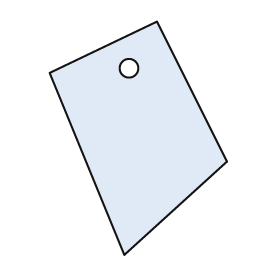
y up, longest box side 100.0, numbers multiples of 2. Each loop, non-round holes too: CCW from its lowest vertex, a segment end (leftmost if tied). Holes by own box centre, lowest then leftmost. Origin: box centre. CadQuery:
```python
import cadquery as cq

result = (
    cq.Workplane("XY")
    .moveTo(-6.0, -50.0)
    .lineTo(38.0, -10.0)
    .lineTo(8.0, 50.0)
    .lineTo(-38.0, 28.0)
    .close()
    .moveTo(-4.0, 30.0)
    .circle(4.0)
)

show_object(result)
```